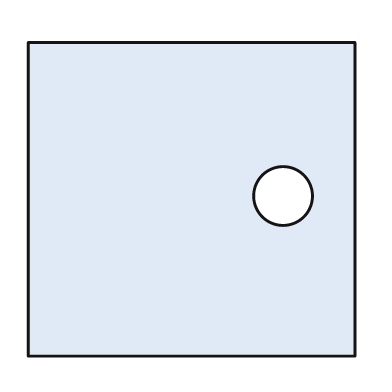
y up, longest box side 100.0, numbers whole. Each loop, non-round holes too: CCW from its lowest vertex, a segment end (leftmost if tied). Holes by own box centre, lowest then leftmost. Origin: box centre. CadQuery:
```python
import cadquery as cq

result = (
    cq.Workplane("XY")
    .moveTo(-50.0, -48.0)
    .lineTo(50.0, -48.0)
    .lineTo(50.0, 48.0)
    .lineTo(-50.0, 48.0)
    .close()
    .moveTo(28.0, 1.0)
    .circle(9.0)
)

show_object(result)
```